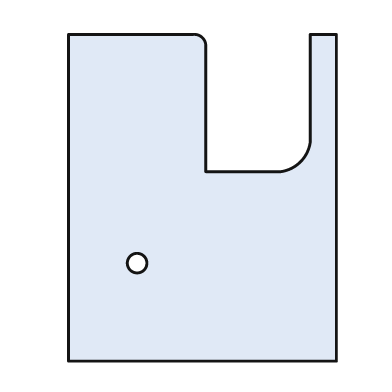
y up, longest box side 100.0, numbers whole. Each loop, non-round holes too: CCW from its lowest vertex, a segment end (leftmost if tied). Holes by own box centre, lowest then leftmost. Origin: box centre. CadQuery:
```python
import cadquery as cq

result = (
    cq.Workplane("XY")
    .moveTo(-41.0, -50.0)
    .lineTo(41.0, -50.0)
    .lineTo(41.0, 50.0)
    .lineTo(33.0, 50.0)
    .lineTo(33.0, 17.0)
    .threePointArc((30.0, 11.0), (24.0, 8.0))
    .lineTo(1.0, 8.0)
    .lineTo(1.0, 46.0)
    .threePointArc((0.0, 49.0), (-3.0, 50.0))
    .lineTo(-41.0, 50.0)
    .close()
    .moveTo(-20.0, -20.0)
    .circle(3.0)
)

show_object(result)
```